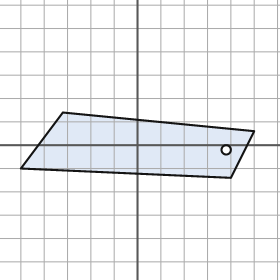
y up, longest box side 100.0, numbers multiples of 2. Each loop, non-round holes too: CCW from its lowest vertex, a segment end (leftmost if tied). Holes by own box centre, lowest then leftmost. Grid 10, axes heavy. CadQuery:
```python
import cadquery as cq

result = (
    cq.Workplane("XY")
    .moveTo(40.0, -14.0)
    .lineTo(50.0, 6.0)
    .lineTo(-32.0, 14.0)
    .lineTo(-50.0, -10.0)
    .close()
    .moveTo(38.0, -2.0)
    .circle(2.0)
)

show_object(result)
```